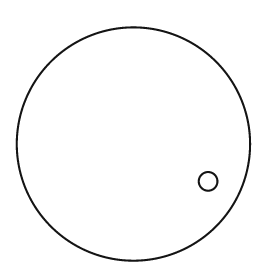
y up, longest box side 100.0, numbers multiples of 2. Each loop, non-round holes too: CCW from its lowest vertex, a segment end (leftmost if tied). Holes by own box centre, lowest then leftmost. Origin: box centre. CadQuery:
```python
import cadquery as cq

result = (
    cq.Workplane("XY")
    .moveTo(0.0, 0.0)
    .circle(50.0)
    .moveTo(32.0, -16.0)
    .circle(4.0)
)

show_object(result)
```